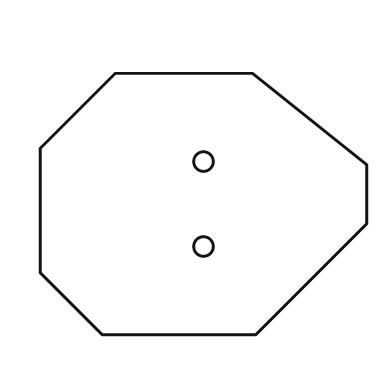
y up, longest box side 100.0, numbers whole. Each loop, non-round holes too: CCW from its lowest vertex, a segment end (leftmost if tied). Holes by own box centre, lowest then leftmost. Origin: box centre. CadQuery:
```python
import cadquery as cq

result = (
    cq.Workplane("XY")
    .moveTo(-31.0, -40.0)
    .lineTo(16.0, -40.0)
    .lineTo(50.0, -6.0)
    .lineTo(50.0, 12.0)
    .lineTo(15.0, 40.0)
    .lineTo(-27.0, 40.0)
    .lineTo(-50.0, 17.0)
    .lineTo(-50.0, -21.0)
    .close()
    .moveTo(0.0, -13.0)
    .circle(3.0)
    .moveTo(0.0, 13.0)
    .circle(3.0)
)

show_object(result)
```